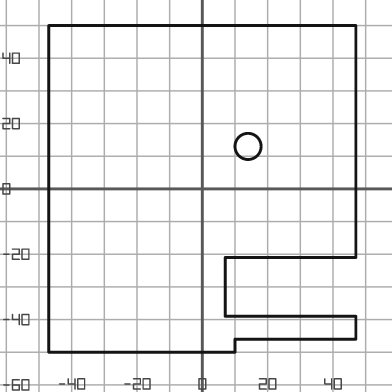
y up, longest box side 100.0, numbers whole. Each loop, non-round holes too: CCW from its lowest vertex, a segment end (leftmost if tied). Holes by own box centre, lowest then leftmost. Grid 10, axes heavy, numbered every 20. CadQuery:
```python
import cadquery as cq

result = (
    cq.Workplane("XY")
    .moveTo(-47.0, -50.0)
    .lineTo(10.0, -50.0)
    .lineTo(10.0, -46.0)
    .lineTo(47.0, -46.0)
    .lineTo(47.0, -39.0)
    .lineTo(7.0, -39.0)
    .lineTo(7.0, -21.0)
    .lineTo(47.0, -21.0)
    .lineTo(47.0, 50.0)
    .lineTo(-47.0, 50.0)
    .close()
    .moveTo(14.0, 13.0)
    .circle(4.0)
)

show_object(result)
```